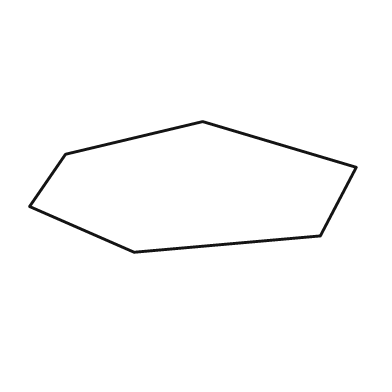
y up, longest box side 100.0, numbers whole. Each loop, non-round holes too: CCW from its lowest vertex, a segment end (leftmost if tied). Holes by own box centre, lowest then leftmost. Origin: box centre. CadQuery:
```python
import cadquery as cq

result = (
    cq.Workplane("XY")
    .moveTo(-18.0, -20.0)
    .lineTo(39.0, -15.0)
    .lineTo(50.0, 6.0)
    .lineTo(3.0, 20.0)
    .lineTo(-39.0, 10.0)
    .lineTo(-50.0, -6.0)
    .close()
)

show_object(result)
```